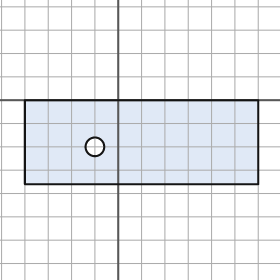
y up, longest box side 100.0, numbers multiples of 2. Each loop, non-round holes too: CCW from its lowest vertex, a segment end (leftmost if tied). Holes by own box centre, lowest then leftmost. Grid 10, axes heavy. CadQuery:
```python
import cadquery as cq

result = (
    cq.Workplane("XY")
    .moveTo(-40.0, -36.0)
    .lineTo(60.0, -36.0)
    .lineTo(60.0, 0.0)
    .lineTo(-40.0, 0.0)
    .close()
    .moveTo(-10.0, -20.0)
    .circle(4.0)
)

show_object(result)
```